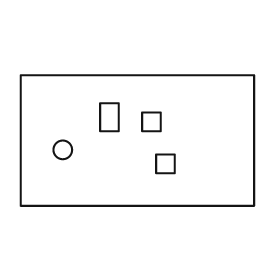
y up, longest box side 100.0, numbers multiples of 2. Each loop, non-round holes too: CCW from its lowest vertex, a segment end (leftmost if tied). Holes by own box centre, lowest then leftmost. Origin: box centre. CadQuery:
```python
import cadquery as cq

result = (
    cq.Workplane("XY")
    .moveTo(-50.0, -28.0)
    .lineTo(50.0, -28.0)
    .lineTo(50.0, 28.0)
    .lineTo(-50.0, 28.0)
    .close()
    .moveTo(8.0, -14.0)
    .lineTo(16.0, -14.0)
    .lineTo(16.0, -6.0)
    .lineTo(8.0, -6.0)
    .close()
    .moveTo(-32.0, -4.0)
    .circle(4.0)
    .moveTo(2.0, 4.0)
    .lineTo(10.0, 4.0)
    .lineTo(10.0, 12.0)
    .lineTo(2.0, 12.0)
    .close()
    .moveTo(-16.0, 4.0)
    .lineTo(-8.0, 4.0)
    .lineTo(-8.0, 16.0)
    .lineTo(-16.0, 16.0)
    .close()
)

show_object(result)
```